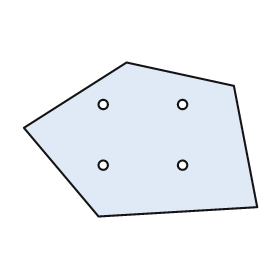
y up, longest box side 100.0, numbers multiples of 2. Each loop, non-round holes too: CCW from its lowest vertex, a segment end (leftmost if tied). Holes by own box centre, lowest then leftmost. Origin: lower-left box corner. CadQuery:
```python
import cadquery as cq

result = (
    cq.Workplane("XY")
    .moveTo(32.0, 0.0)
    .lineTo(100.0, 4.0)
    .lineTo(90.0, 56.0)
    .lineTo(44.0, 66.0)
    .lineTo(0.0, 38.0)
    .close()
    .moveTo(34.0, 22.0)
    .circle(2.0)
    .moveTo(68.0, 22.0)
    .circle(2.0)
    .moveTo(34.0, 48.0)
    .circle(2.0)
    .moveTo(68.0, 48.0)
    .circle(2.0)
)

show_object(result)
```